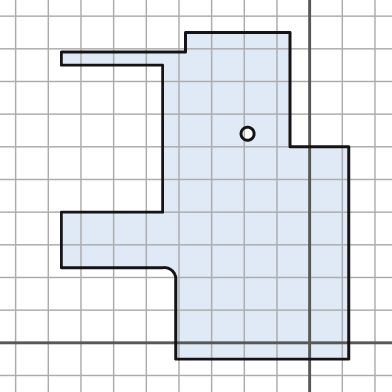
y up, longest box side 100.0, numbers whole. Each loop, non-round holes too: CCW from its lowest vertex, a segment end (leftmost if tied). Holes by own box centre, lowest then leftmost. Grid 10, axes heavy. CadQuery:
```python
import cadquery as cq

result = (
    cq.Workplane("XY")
    .moveTo(-41.0, -5.0)
    .lineTo(12.0, -5.0)
    .lineTo(12.0, 60.0)
    .lineTo(-6.0, 60.0)
    .lineTo(-6.0, 95.0)
    .lineTo(-38.0, 95.0)
    .lineTo(-38.0, 89.0)
    .lineTo(-76.0, 89.0)
    .lineTo(-76.0, 85.0)
    .lineTo(-45.0, 85.0)
    .lineTo(-45.0, 40.0)
    .lineTo(-76.0, 40.0)
    .lineTo(-76.0, 23.0)
    .lineTo(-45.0, 23.0)
    .threePointArc((-42.0, 22.0), (-41.0, 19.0))
    .close()
    .moveTo(-19.0, 64.0)
    .circle(2.0)
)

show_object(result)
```